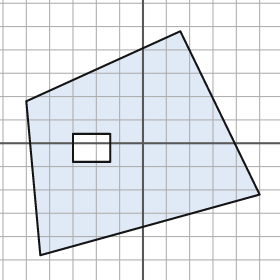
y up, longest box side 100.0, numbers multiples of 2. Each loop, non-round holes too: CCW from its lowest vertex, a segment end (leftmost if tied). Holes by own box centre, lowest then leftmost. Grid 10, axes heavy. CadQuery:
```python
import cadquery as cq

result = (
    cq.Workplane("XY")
    .moveTo(-44.0, -48.0)
    .lineTo(50.0, -22.0)
    .lineTo(16.0, 48.0)
    .lineTo(-50.0, 18.0)
    .close()
    .moveTo(-30.0, -8.0)
    .lineTo(-14.0, -8.0)
    .lineTo(-14.0, 4.0)
    .lineTo(-30.0, 4.0)
    .close()
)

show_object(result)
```